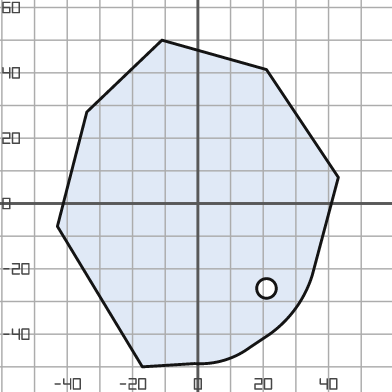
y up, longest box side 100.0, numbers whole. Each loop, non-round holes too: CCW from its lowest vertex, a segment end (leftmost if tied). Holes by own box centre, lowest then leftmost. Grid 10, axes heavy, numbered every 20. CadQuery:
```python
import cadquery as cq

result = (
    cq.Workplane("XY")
    .moveTo(-17.0, -50.0)
    .lineTo(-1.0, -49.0)
    .threePointArc((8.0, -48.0), (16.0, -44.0))
    .lineTo(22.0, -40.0)
    .threePointArc((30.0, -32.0), (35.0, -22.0))
    .lineTo(43.0, 8.0)
    .lineTo(21.0, 41.0)
    .lineTo(-11.0, 50.0)
    .lineTo(-34.0, 28.0)
    .lineTo(-43.0, -7.0)
    .close()
    .moveTo(21.0, -26.0)
    .circle(3.0)
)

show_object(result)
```